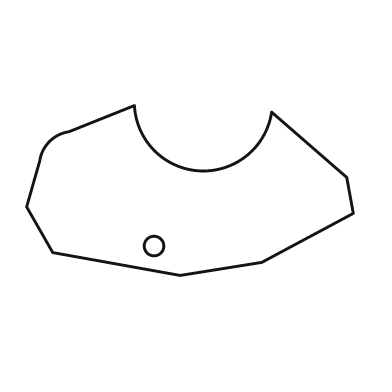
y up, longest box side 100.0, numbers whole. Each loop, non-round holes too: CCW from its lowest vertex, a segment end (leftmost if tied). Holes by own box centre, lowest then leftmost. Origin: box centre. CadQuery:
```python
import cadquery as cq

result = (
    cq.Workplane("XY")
    .moveTo(-3.0, -26.0)
    .lineTo(22.0, -22.0)
    .lineTo(50.0, -7.0)
    .lineTo(48.0, 4.0)
    .lineTo(25.0, 24.0)
    .threePointArc((3.0, 6.0), (-17.0, 26.0))
    .lineTo(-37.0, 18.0)
    .threePointArc((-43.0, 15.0), (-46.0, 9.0))
    .lineTo(-50.0, -5.0)
    .lineTo(-42.0, -19.0)
    .close()
    .moveTo(-11.0, -17.0)
    .circle(3.0)
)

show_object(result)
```